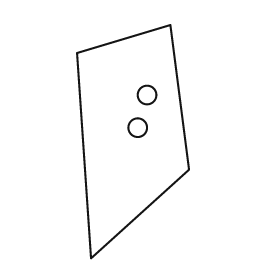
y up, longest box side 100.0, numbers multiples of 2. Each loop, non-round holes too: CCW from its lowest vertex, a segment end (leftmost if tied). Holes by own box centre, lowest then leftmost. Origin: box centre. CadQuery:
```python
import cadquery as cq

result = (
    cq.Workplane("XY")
    .moveTo(-18.0, -50.0)
    .lineTo(24.0, -12.0)
    .lineTo(16.0, 50.0)
    .lineTo(-24.0, 38.0)
    .close()
    .moveTo(2.0, 6.0)
    .circle(4.0)
    .moveTo(6.0, 20.0)
    .circle(4.0)
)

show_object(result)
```